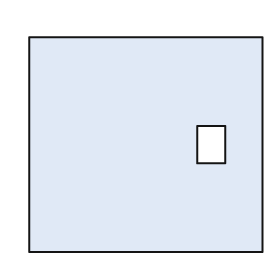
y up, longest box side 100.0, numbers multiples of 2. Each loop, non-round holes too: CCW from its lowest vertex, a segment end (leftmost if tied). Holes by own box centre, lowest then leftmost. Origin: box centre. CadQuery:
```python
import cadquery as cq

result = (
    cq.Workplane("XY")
    .moveTo(-50.0, -46.0)
    .lineTo(50.0, -46.0)
    .lineTo(50.0, 46.0)
    .lineTo(-50.0, 46.0)
    .close()
    .moveTo(22.0, -8.0)
    .lineTo(34.0, -8.0)
    .lineTo(34.0, 8.0)
    .lineTo(22.0, 8.0)
    .close()
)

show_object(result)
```